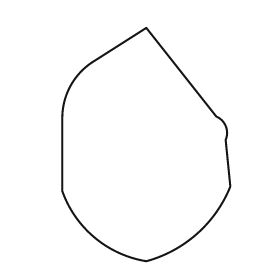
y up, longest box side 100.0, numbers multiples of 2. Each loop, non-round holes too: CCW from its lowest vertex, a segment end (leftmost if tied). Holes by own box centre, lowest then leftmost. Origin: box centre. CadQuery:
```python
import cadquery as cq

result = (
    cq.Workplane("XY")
    .moveTo(0.0, -50.0)
    .threePointArc((22.0, -38.0), (36.0, -18.0))
    .lineTo(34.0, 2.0)
    .threePointArc((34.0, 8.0), (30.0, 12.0))
    .lineTo(0.0, 50.0)
    .lineTo(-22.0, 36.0)
    .threePointArc((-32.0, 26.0), (-36.0, 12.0))
    .lineTo(-36.0, -20.0)
    .threePointArc((-22.0, -40.0), (0.0, -50.0))
    .close()
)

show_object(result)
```